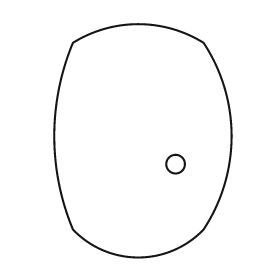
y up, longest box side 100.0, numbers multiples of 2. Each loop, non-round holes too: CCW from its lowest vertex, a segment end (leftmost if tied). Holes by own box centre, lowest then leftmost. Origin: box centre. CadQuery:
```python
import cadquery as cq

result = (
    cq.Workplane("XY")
    .moveTo(-30.0, -38.0)
    .threePointArc((-2.0, -50.0), (26.0, -38.0))
    .threePointArc((38.0, 2.0), (26.0, 42.0))
    .threePointArc((-2.0, 50.0), (-30.0, 42.0))
    .threePointArc((-38.0, 2.0), (-30.0, -38.0))
    .close()
    .moveTo(14.0, -10.0)
    .circle(4.0)
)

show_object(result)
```